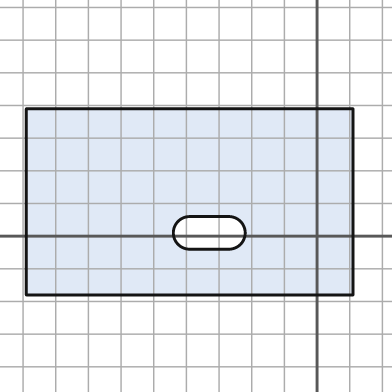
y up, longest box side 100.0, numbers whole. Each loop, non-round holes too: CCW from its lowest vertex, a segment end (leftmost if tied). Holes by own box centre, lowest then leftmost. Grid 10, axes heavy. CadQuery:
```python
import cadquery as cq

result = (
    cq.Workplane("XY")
    .moveTo(-89.0, -18.0)
    .lineTo(11.0, -18.0)
    .lineTo(11.0, 39.0)
    .lineTo(-89.0, 39.0)
    .close()
    .moveTo(-39.0, -4.0)
    .lineTo(-27.0, -4.0)
    .threePointArc((-22.0, 1.0), (-27.0, 6.0))
    .lineTo(-39.0, 6.0)
    .threePointArc((-44.0, 1.0), (-39.0, -4.0))
    .close()
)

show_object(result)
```